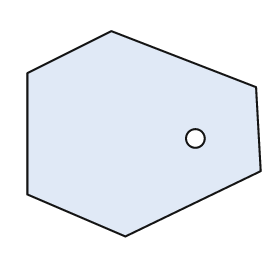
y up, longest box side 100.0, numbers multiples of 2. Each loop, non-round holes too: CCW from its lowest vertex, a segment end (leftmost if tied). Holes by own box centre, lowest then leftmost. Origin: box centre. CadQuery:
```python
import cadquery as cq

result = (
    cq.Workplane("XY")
    .moveTo(-8.0, -44.0)
    .lineTo(50.0, -16.0)
    .lineTo(48.0, 20.0)
    .lineTo(-14.0, 44.0)
    .lineTo(-50.0, 26.0)
    .lineTo(-50.0, -26.0)
    .close()
    .moveTo(22.0, -2.0)
    .circle(4.0)
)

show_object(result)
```